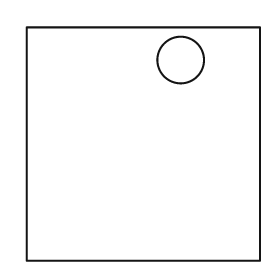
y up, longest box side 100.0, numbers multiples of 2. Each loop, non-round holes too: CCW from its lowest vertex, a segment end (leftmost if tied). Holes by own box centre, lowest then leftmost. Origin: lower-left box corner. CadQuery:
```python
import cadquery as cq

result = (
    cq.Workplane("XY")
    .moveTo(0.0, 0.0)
    .lineTo(100.0, 0.0)
    .lineTo(100.0, 100.0)
    .lineTo(0.0, 100.0)
    .close()
    .moveTo(66.0, 86.0)
    .circle(10.0)
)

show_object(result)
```